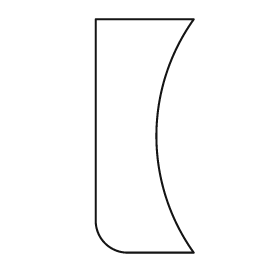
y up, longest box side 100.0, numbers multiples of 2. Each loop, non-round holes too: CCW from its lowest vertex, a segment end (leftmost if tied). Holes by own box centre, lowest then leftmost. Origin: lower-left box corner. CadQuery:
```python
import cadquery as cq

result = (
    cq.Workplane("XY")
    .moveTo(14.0, 0.0)
    .lineTo(42.0, 0.0)
    .threePointArc((26.0, 50.0), (42.0, 100.0))
    .lineTo(0.0, 100.0)
    .lineTo(0.0, 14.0)
    .threePointArc((4.0, 4.0), (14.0, 0.0))
    .close()
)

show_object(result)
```